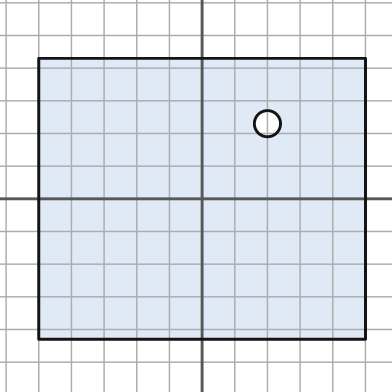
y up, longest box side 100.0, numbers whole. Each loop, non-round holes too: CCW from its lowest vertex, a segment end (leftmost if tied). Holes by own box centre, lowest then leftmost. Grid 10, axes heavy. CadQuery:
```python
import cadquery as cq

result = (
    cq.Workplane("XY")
    .moveTo(-50.0, -43.0)
    .lineTo(50.0, -43.0)
    .lineTo(50.0, 43.0)
    .lineTo(-50.0, 43.0)
    .close()
    .moveTo(20.0, 23.0)
    .circle(4.0)
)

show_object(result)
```